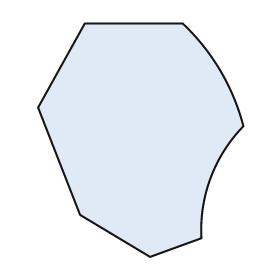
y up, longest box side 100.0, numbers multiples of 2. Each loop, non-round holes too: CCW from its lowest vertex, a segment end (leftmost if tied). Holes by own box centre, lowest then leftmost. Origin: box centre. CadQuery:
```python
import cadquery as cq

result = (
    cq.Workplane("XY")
    .moveTo(4.0, -50.0)
    .lineTo(26.0, -42.0)
    .threePointArc((30.0, -16.0), (44.0, 6.0))
    .threePointArc((34.0, 30.0), (18.0, 50.0))
    .lineTo(-24.0, 50.0)
    .lineTo(-44.0, 14.0)
    .lineTo(-26.0, -32.0)
    .close()
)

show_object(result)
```